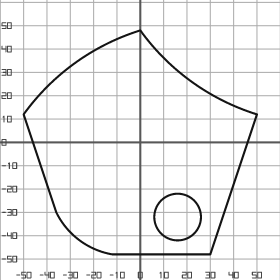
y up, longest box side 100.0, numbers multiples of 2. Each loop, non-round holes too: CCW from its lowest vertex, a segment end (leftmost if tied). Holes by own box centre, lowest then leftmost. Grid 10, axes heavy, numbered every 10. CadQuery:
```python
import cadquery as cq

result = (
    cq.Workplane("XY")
    .moveTo(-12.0, -48.0)
    .lineTo(30.0, -48.0)
    .lineTo(50.0, 12.0)
    .threePointArc((22.0, 26.0), (0.0, 48.0))
    .threePointArc((-28.0, 34.0), (-50.0, 12.0))
    .lineTo(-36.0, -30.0)
    .threePointArc((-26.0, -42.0), (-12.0, -48.0))
    .close()
    .moveTo(16.0, -32.0)
    .circle(10.0)
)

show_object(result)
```